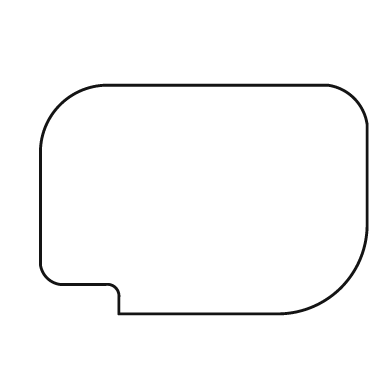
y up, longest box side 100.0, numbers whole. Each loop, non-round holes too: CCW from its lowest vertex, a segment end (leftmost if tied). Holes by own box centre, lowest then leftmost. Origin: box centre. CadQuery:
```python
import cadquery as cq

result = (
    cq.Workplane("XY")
    .moveTo(-26.0, -35.0)
    .lineTo(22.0, -35.0)
    .threePointArc((42.0, -27.0), (50.0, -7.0))
    .lineTo(50.0, 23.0)
    .threePointArc((46.0, 31.0), (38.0, 35.0))
    .lineTo(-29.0, 35.0)
    .threePointArc((-44.0, 29.0), (-50.0, 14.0))
    .lineTo(-50.0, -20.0)
    .threePointArc((-48.0, -24.0), (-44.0, -26.0))
    .lineTo(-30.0, -26.0)
    .threePointArc((-27.0, -27.0), (-26.0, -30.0))
    .close()
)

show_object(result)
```